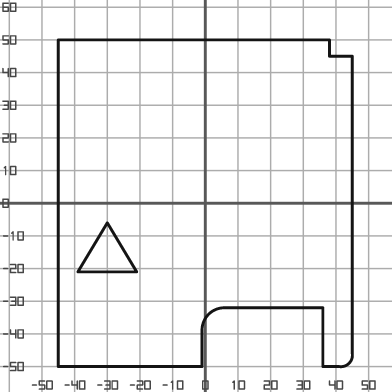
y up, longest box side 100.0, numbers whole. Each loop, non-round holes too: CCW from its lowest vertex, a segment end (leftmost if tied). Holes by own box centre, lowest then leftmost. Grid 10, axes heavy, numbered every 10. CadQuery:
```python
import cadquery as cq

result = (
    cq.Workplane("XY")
    .moveTo(-45.0, -50.0)
    .lineTo(-1.0, -50.0)
    .lineTo(-1.0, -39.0)
    .threePointArc((1.0, -34.0), (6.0, -32.0))
    .lineTo(36.0, -32.0)
    .lineTo(36.0, -50.0)
    .lineTo(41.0, -50.0)
    .threePointArc((44.0, -49.0), (45.0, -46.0))
    .lineTo(45.0, 45.0)
    .lineTo(38.0, 45.0)
    .lineTo(38.0, 50.0)
    .lineTo(-45.0, 50.0)
    .close()
    .moveTo(-39.0, -21.0)
    .lineTo(-21.0, -21.0)
    .lineTo(-30.0, -6.0)
    .close()
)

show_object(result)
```